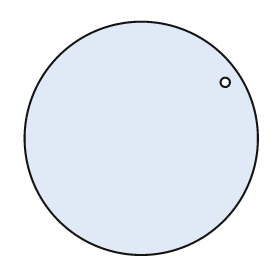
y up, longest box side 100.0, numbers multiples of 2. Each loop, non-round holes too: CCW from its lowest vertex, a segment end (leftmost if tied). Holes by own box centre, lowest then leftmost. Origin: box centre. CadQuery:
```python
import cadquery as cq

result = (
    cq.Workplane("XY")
    .moveTo(0.0, 0.0)
    .circle(50.0)
    .moveTo(36.0, 24.0)
    .circle(2.0)
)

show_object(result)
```